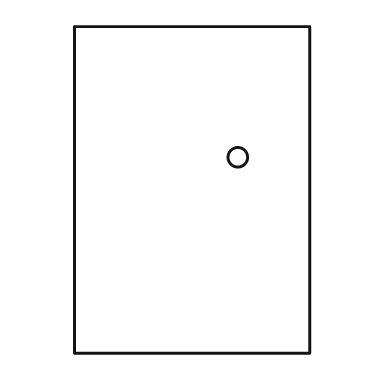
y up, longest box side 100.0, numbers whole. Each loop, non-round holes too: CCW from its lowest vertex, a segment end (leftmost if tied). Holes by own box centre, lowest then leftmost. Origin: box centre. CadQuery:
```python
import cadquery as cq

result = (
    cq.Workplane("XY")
    .moveTo(-36.0, -50.0)
    .lineTo(36.0, -50.0)
    .lineTo(36.0, 50.0)
    .lineTo(-36.0, 50.0)
    .close()
    .moveTo(14.0, 10.0)
    .circle(3.0)
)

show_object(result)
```